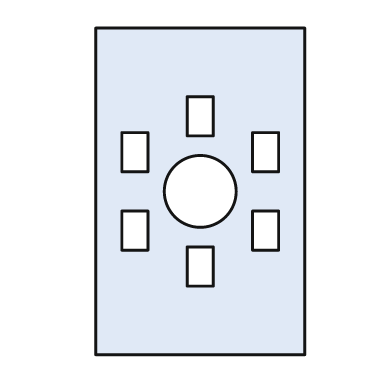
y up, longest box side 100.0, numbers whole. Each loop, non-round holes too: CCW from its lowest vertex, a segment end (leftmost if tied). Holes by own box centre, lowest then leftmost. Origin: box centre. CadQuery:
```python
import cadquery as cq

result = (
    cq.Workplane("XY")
    .moveTo(-32.0, -50.0)
    .lineTo(32.0, -50.0)
    .lineTo(32.0, 50.0)
    .lineTo(-32.0, 50.0)
    .close()
    .moveTo(-4.0, -29.0)
    .lineTo(4.0, -29.0)
    .lineTo(4.0, -17.0)
    .lineTo(-4.0, -17.0)
    .close()
    .moveTo(-24.0, -18.0)
    .lineTo(-16.0, -18.0)
    .lineTo(-16.0, -6.0)
    .lineTo(-24.0, -6.0)
    .close()
    .moveTo(16.0, -18.0)
    .lineTo(24.0, -18.0)
    .lineTo(24.0, -6.0)
    .lineTo(16.0, -6.0)
    .close()
    .moveTo(0.0, 0.0)
    .circle(11.0)
    .moveTo(-24.0, 6.0)
    .lineTo(-16.0, 6.0)
    .lineTo(-16.0, 18.0)
    .lineTo(-24.0, 18.0)
    .close()
    .moveTo(16.0, 6.0)
    .lineTo(24.0, 6.0)
    .lineTo(24.0, 18.0)
    .lineTo(16.0, 18.0)
    .close()
    .moveTo(-4.0, 17.0)
    .lineTo(4.0, 17.0)
    .lineTo(4.0, 29.0)
    .lineTo(-4.0, 29.0)
    .close()
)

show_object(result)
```